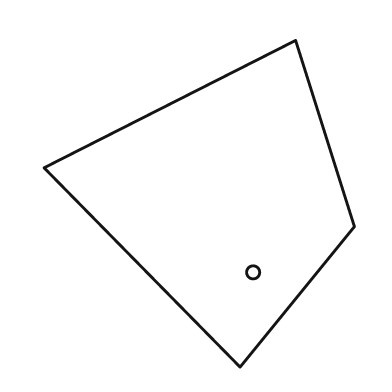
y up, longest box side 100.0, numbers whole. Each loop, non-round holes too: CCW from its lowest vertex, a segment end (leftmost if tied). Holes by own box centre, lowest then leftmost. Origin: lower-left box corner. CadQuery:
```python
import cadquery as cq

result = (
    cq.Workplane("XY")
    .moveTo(60.0, 0.0)
    .lineTo(95.0, 43.0)
    .lineTo(77.0, 100.0)
    .lineTo(0.0, 61.0)
    .close()
    .moveTo(64.0, 29.0)
    .circle(2.0)
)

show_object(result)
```